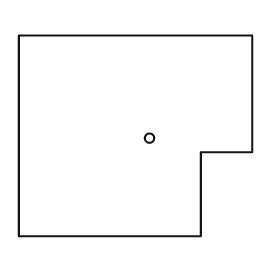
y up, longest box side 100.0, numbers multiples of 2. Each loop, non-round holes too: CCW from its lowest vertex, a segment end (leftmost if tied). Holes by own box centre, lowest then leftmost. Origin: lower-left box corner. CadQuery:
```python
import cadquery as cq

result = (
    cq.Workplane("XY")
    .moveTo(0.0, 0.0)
    .lineTo(78.0, 0.0)
    .lineTo(78.0, 36.0)
    .lineTo(100.0, 36.0)
    .lineTo(100.0, 86.0)
    .lineTo(0.0, 86.0)
    .close()
    .moveTo(56.0, 42.0)
    .circle(2.0)
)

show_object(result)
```